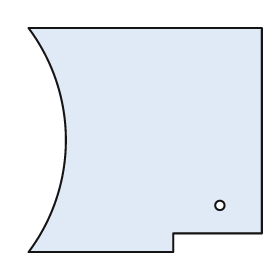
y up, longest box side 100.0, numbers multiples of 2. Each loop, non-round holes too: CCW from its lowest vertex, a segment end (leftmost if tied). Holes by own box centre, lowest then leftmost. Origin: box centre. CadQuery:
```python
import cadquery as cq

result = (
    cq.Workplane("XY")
    .moveTo(-50.0, -48.0)
    .lineTo(12.0, -48.0)
    .lineTo(12.0, -40.0)
    .lineTo(50.0, -40.0)
    .lineTo(50.0, 48.0)
    .lineTo(-50.0, 48.0)
    .threePointArc((-34.0, 0.0), (-50.0, -48.0))
    .close()
    .moveTo(32.0, -28.0)
    .circle(2.0)
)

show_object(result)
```